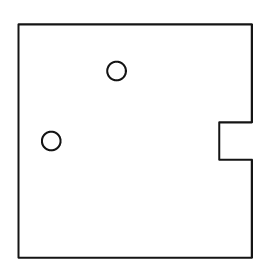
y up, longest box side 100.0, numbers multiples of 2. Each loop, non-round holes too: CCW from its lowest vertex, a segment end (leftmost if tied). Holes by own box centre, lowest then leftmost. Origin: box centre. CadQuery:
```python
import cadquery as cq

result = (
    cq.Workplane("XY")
    .moveTo(-50.0, -50.0)
    .lineTo(50.0, -50.0)
    .lineTo(50.0, -8.0)
    .lineTo(36.0, -8.0)
    .lineTo(36.0, 8.0)
    .lineTo(50.0, 8.0)
    .lineTo(50.0, 50.0)
    .lineTo(-50.0, 50.0)
    .close()
    .moveTo(-36.0, 0.0)
    .circle(4.0)
    .moveTo(-8.0, 30.0)
    .circle(4.0)
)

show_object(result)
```